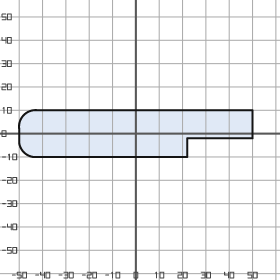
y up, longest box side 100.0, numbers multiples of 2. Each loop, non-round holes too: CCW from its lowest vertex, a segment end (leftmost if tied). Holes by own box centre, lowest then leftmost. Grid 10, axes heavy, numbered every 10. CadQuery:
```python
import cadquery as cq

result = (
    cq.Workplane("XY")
    .moveTo(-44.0, -10.0)
    .lineTo(22.0, -10.0)
    .lineTo(22.0, -2.0)
    .lineTo(50.0, -2.0)
    .lineTo(50.0, 10.0)
    .lineTo(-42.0, 10.0)
    .threePointArc((-48.0, 8.0), (-50.0, 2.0))
    .lineTo(-50.0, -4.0)
    .threePointArc((-48.0, -8.0), (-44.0, -10.0))
    .close()
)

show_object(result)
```